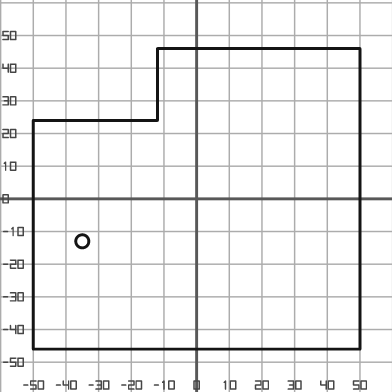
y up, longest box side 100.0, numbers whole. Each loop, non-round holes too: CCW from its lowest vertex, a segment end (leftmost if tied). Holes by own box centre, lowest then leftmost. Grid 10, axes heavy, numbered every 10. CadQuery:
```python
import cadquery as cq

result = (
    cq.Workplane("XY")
    .moveTo(-50.0, -46.0)
    .lineTo(50.0, -46.0)
    .lineTo(50.0, 46.0)
    .lineTo(-12.0, 46.0)
    .lineTo(-12.0, 24.0)
    .lineTo(-50.0, 24.0)
    .close()
    .moveTo(-35.0, -13.0)
    .circle(2.0)
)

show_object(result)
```